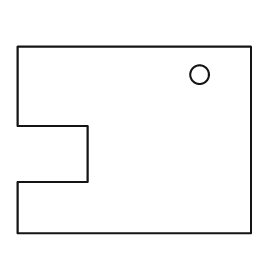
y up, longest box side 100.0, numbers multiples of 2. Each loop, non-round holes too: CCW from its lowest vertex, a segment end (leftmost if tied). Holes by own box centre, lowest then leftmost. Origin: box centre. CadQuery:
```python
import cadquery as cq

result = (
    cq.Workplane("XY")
    .moveTo(-50.0, -40.0)
    .lineTo(50.0, -40.0)
    .lineTo(50.0, 40.0)
    .lineTo(-50.0, 40.0)
    .lineTo(-50.0, 6.0)
    .lineTo(-20.0, 6.0)
    .lineTo(-20.0, -18.0)
    .lineTo(-50.0, -18.0)
    .close()
    .moveTo(28.0, 28.0)
    .circle(4.0)
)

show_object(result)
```